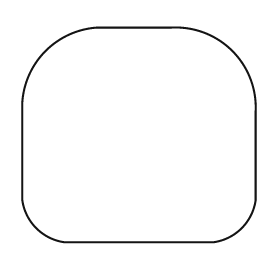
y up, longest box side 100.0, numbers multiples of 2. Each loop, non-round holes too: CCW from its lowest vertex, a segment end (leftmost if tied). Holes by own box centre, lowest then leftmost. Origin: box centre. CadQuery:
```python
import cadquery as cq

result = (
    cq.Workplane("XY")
    .moveTo(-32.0, -46.0)
    .lineTo(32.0, -46.0)
    .threePointArc((44.0, -40.0), (50.0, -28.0))
    .lineTo(50.0, 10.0)
    .threePointArc((40.0, 36.0), (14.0, 46.0))
    .lineTo(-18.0, 46.0)
    .threePointArc((-40.0, 36.0), (-50.0, 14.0))
    .lineTo(-50.0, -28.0)
    .threePointArc((-44.0, -40.0), (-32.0, -46.0))
    .close()
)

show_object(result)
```